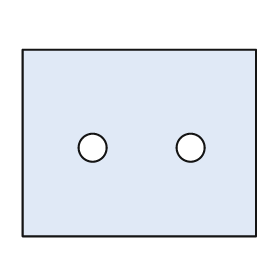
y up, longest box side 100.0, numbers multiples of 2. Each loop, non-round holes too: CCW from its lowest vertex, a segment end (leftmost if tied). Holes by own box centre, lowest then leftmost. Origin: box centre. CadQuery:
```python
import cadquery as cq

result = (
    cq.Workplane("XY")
    .moveTo(-50.0, -40.0)
    .lineTo(50.0, -40.0)
    .lineTo(50.0, 40.0)
    .lineTo(-50.0, 40.0)
    .close()
    .moveTo(-20.0, -2.0)
    .circle(6.0)
    .moveTo(22.0, -2.0)
    .circle(6.0)
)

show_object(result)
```